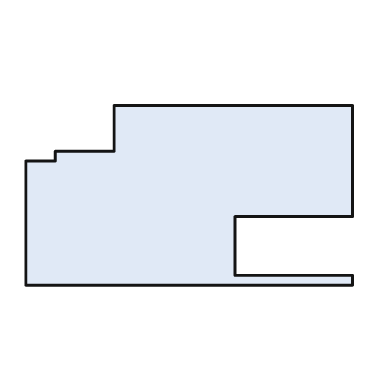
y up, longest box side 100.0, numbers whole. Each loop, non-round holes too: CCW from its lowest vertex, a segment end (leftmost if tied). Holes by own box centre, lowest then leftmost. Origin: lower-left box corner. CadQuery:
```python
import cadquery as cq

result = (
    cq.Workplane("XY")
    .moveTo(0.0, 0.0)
    .lineTo(100.0, 0.0)
    .lineTo(100.0, 3.0)
    .lineTo(64.0, 3.0)
    .lineTo(64.0, 21.0)
    .lineTo(100.0, 21.0)
    .lineTo(100.0, 55.0)
    .lineTo(27.0, 55.0)
    .lineTo(27.0, 41.0)
    .lineTo(9.0, 41.0)
    .lineTo(9.0, 38.0)
    .lineTo(0.0, 38.0)
    .close()
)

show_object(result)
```